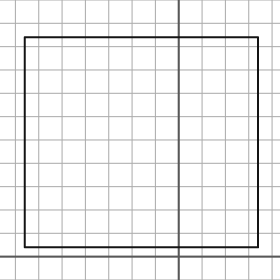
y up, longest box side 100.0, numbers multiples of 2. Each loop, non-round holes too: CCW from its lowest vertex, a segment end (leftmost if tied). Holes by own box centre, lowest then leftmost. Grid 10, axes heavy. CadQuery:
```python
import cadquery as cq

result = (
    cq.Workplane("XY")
    .moveTo(-66.0, 4.0)
    .lineTo(34.0, 4.0)
    .lineTo(34.0, 94.0)
    .lineTo(-66.0, 94.0)
    .close()
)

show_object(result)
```